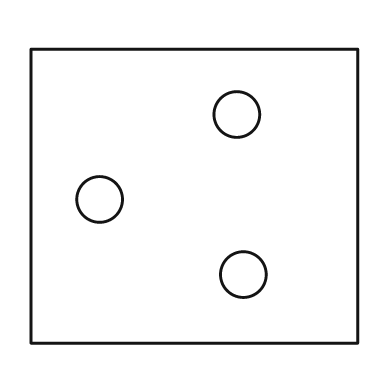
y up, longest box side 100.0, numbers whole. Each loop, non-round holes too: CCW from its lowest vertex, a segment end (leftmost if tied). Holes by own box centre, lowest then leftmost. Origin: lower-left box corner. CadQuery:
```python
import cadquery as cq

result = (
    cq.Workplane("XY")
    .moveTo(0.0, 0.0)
    .lineTo(100.0, 0.0)
    .lineTo(100.0, 90.0)
    .lineTo(0.0, 90.0)
    .close()
    .moveTo(65.0, 21.0)
    .circle(7.0)
    .moveTo(21.0, 44.0)
    .circle(7.0)
    .moveTo(63.0, 70.0)
    .circle(7.0)
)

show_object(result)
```